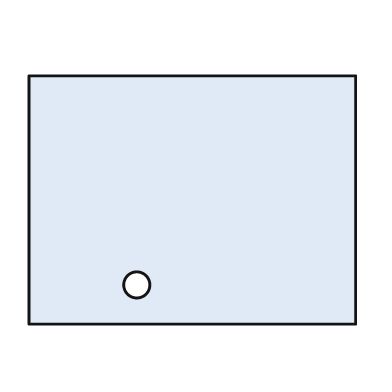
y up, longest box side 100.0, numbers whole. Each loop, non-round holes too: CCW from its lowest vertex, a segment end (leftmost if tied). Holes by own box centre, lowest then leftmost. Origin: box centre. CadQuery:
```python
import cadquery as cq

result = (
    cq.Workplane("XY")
    .moveTo(-50.0, -38.0)
    .lineTo(50.0, -38.0)
    .lineTo(50.0, 38.0)
    .lineTo(-50.0, 38.0)
    .close()
    .moveTo(-17.0, -26.0)
    .circle(4.0)
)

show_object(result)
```